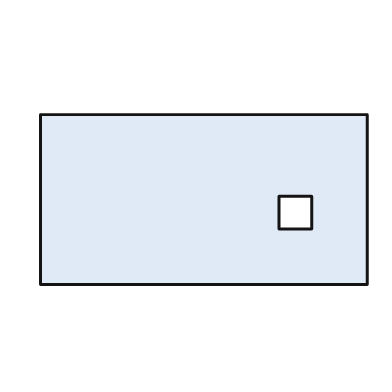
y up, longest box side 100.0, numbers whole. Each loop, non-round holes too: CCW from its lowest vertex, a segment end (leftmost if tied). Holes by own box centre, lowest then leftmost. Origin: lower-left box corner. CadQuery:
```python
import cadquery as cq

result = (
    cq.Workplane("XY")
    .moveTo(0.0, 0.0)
    .lineTo(100.0, 0.0)
    .lineTo(100.0, 52.0)
    .lineTo(0.0, 52.0)
    .close()
    .moveTo(73.0, 17.0)
    .lineTo(83.0, 17.0)
    .lineTo(83.0, 27.0)
    .lineTo(73.0, 27.0)
    .close()
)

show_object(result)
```